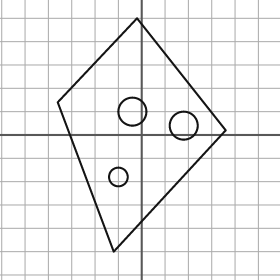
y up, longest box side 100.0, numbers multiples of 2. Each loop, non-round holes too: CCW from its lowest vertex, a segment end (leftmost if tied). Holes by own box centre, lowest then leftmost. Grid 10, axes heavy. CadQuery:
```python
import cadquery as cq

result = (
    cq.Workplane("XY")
    .moveTo(-12.0, -50.0)
    .lineTo(36.0, 2.0)
    .lineTo(-2.0, 50.0)
    .lineTo(-36.0, 14.0)
    .close()
    .moveTo(-10.0, -18.0)
    .circle(4.0)
    .moveTo(18.0, 4.0)
    .circle(6.0)
    .moveTo(-4.0, 10.0)
    .circle(6.0)
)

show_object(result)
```